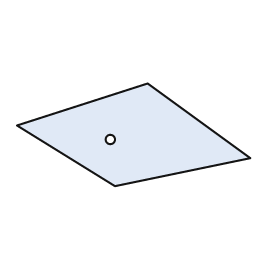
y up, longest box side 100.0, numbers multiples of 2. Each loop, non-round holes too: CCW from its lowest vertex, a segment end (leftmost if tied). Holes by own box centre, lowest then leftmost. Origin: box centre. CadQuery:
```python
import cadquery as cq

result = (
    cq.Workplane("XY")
    .moveTo(-8.0, -22.0)
    .lineTo(50.0, -10.0)
    .lineTo(6.0, 22.0)
    .lineTo(-50.0, 4.0)
    .close()
    .moveTo(-10.0, -2.0)
    .circle(2.0)
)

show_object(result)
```